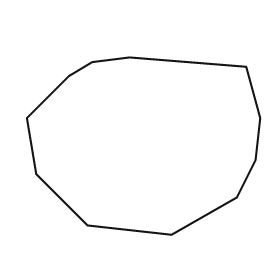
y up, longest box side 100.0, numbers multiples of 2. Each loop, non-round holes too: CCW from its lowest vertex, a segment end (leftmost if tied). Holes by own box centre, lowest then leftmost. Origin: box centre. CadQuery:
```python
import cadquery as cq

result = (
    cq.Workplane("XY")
    .moveTo(12.0, -38.0)
    .lineTo(40.0, -22.0)
    .lineTo(48.0, -6.0)
    .lineTo(50.0, 12.0)
    .lineTo(44.0, 34.0)
    .lineTo(-6.0, 38.0)
    .lineTo(-22.0, 36.0)
    .lineTo(-32.0, 30.0)
    .lineTo(-50.0, 12.0)
    .lineTo(-46.0, -12.0)
    .lineTo(-24.0, -34.0)
    .close()
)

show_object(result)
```